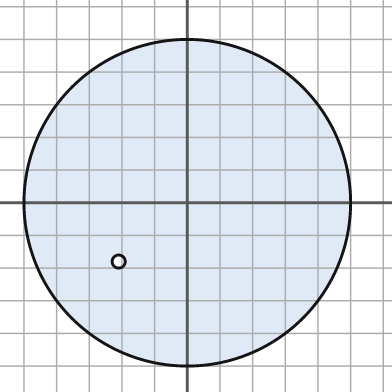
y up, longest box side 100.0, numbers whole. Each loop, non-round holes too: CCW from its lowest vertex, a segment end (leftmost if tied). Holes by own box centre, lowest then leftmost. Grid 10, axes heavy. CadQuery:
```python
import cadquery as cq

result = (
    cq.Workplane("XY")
    .moveTo(0.0, 0.0)
    .circle(50.0)
    .moveTo(-21.0, -18.0)
    .circle(2.0)
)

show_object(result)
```